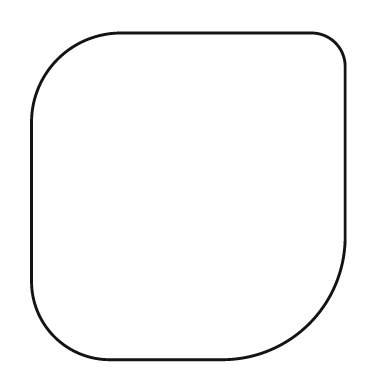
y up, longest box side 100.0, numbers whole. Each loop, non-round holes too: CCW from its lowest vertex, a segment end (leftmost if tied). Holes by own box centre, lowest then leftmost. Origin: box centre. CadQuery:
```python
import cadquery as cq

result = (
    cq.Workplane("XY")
    .moveTo(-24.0, -50.0)
    .lineTo(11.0, -50.0)
    .threePointArc((37.0, -39.0), (48.0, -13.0))
    .lineTo(48.0, 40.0)
    .threePointArc((45.0, 47.0), (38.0, 50.0))
    .lineTo(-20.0, 50.0)
    .threePointArc((-40.0, 42.0), (-48.0, 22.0))
    .lineTo(-48.0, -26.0)
    .threePointArc((-41.0, -43.0), (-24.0, -50.0))
    .close()
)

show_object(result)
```